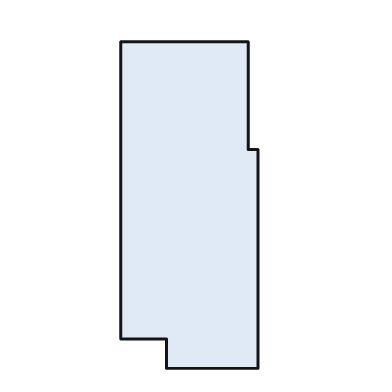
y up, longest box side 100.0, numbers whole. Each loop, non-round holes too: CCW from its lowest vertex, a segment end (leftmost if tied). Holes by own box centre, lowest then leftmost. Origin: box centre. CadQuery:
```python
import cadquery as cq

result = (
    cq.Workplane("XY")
    .moveTo(-7.0, -50.0)
    .lineTo(21.0, -50.0)
    .lineTo(21.0, 17.0)
    .lineTo(18.0, 17.0)
    .lineTo(18.0, 50.0)
    .lineTo(-21.0, 50.0)
    .lineTo(-21.0, -41.0)
    .lineTo(-7.0, -41.0)
    .close()
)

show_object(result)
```